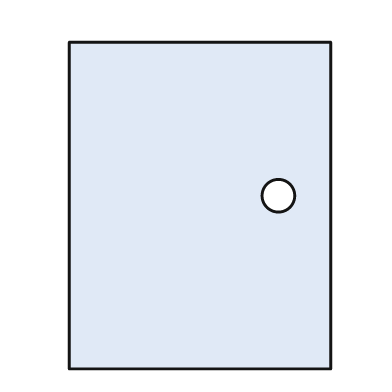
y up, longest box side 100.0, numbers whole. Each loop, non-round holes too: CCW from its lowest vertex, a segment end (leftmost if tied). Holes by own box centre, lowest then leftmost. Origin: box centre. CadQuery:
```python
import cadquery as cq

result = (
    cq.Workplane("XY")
    .moveTo(-40.0, -50.0)
    .lineTo(40.0, -50.0)
    .lineTo(40.0, 50.0)
    .lineTo(-40.0, 50.0)
    .close()
    .moveTo(24.0, 3.0)
    .circle(5.0)
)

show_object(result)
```